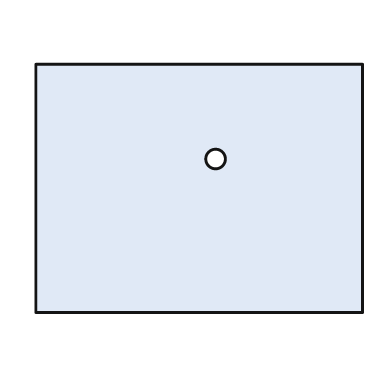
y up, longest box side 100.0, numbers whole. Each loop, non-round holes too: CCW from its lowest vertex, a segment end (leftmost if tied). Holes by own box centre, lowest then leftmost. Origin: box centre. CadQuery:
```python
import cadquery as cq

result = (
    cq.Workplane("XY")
    .moveTo(-50.0, -38.0)
    .lineTo(50.0, -38.0)
    .lineTo(50.0, 38.0)
    .lineTo(-50.0, 38.0)
    .close()
    .moveTo(5.0, 9.0)
    .circle(3.0)
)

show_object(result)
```